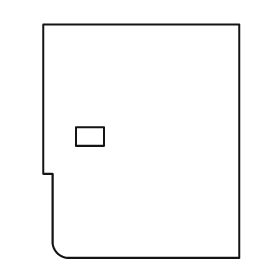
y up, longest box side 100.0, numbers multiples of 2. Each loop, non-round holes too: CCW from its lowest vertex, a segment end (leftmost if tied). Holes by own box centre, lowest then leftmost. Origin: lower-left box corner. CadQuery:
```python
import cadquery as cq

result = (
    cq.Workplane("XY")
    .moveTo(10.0, 0.0)
    .lineTo(84.0, 0.0)
    .lineTo(84.0, 100.0)
    .lineTo(0.0, 100.0)
    .lineTo(0.0, 36.0)
    .lineTo(4.0, 36.0)
    .lineTo(4.0, 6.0)
    .threePointArc((6.0, 2.0), (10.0, 0.0))
    .close()
    .moveTo(14.0, 48.0)
    .lineTo(26.0, 48.0)
    .lineTo(26.0, 56.0)
    .lineTo(14.0, 56.0)
    .close()
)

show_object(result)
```